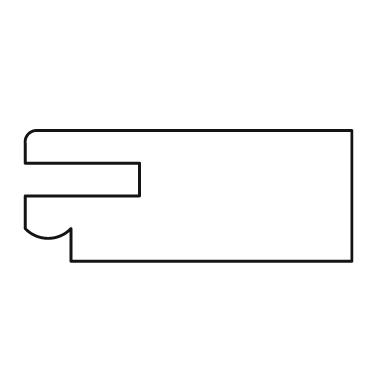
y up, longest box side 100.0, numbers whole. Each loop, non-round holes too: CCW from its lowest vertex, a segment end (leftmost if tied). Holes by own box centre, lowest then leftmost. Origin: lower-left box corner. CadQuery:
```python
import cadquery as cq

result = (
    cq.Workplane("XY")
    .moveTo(14.0, 0.0)
    .lineTo(100.0, 0.0)
    .lineTo(100.0, 40.0)
    .lineTo(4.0, 40.0)
    .threePointArc((1.0, 39.0), (0.0, 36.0))
    .lineTo(0.0, 30.0)
    .lineTo(35.0, 30.0)
    .lineTo(35.0, 20.0)
    .lineTo(0.0, 20.0)
    .lineTo(0.0, 10.0)
    .threePointArc((7.0, 7.0), (14.0, 10.0))
    .close()
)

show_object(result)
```